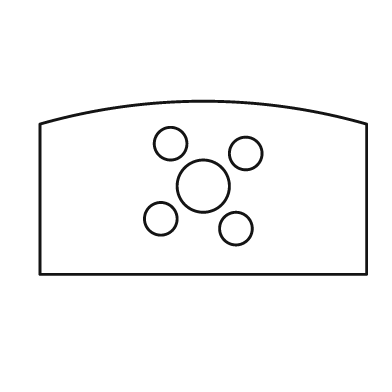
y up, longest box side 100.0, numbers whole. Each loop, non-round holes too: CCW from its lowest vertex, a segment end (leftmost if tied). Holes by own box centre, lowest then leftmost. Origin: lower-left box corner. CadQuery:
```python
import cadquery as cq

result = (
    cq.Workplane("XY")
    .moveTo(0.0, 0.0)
    .lineTo(100.0, 0.0)
    .lineTo(100.0, 46.0)
    .threePointArc((50.0, 53.0), (0.0, 46.0))
    .close()
    .moveTo(60.0, 14.0)
    .circle(5.0)
    .moveTo(37.0, 17.0)
    .circle(5.0)
    .moveTo(50.0, 27.0)
    .circle(8.0)
    .moveTo(63.0, 37.0)
    .circle(5.0)
    .moveTo(40.0, 40.0)
    .circle(5.0)
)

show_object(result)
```